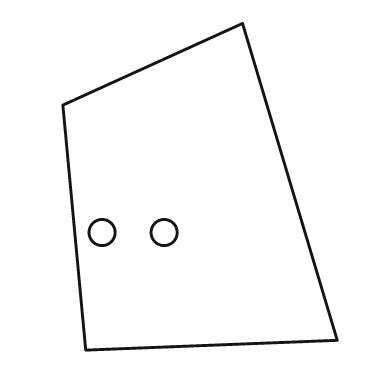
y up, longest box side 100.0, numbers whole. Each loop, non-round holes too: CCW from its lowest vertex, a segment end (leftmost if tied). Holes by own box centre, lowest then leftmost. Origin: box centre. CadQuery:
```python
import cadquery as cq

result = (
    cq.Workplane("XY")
    .moveTo(-35.0, -50.0)
    .lineTo(42.0, -47.0)
    .lineTo(13.0, 50.0)
    .lineTo(-42.0, 25.0)
    .close()
    .moveTo(-30.0, -14.0)
    .circle(4.0)
    .moveTo(-11.0, -14.0)
    .circle(4.0)
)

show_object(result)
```